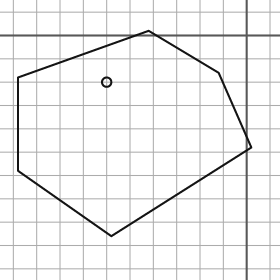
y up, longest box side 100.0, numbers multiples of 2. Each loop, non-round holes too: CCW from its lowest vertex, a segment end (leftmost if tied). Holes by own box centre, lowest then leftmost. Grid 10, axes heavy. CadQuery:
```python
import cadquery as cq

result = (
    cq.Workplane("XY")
    .moveTo(-58.0, -86.0)
    .lineTo(2.0, -48.0)
    .lineTo(-12.0, -16.0)
    .lineTo(-42.0, 2.0)
    .lineTo(-98.0, -18.0)
    .lineTo(-98.0, -58.0)
    .close()
    .moveTo(-60.0, -20.0)
    .circle(2.0)
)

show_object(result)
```